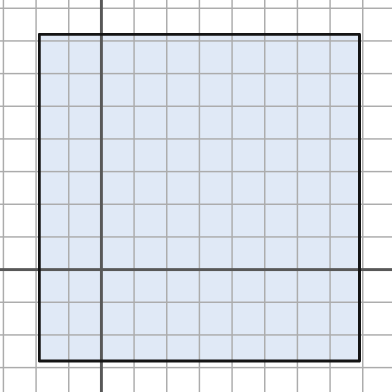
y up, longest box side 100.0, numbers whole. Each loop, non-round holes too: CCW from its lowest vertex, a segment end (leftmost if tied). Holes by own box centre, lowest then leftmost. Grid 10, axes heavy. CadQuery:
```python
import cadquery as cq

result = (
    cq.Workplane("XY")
    .moveTo(-19.0, -28.0)
    .lineTo(79.0, -28.0)
    .lineTo(79.0, 72.0)
    .lineTo(-19.0, 72.0)
    .close()
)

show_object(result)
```